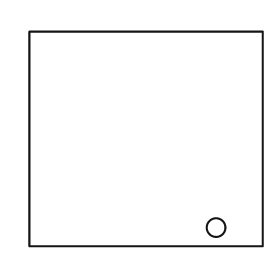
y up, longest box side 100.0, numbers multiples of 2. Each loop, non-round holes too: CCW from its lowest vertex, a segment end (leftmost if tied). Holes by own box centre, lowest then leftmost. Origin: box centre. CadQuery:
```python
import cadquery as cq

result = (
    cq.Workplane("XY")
    .moveTo(-50.0, -46.0)
    .lineTo(50.0, -46.0)
    .lineTo(50.0, 46.0)
    .lineTo(-50.0, 46.0)
    .close()
    .moveTo(30.0, -38.0)
    .circle(4.0)
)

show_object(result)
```